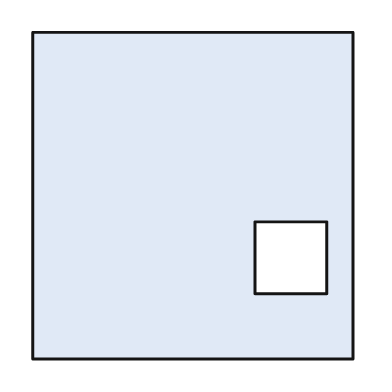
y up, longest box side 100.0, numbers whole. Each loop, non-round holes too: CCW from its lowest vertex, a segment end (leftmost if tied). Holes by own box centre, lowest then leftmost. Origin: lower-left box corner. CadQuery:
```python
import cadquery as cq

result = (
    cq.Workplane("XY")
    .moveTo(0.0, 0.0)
    .lineTo(98.0, 0.0)
    .lineTo(98.0, 100.0)
    .lineTo(0.0, 100.0)
    .close()
    .moveTo(68.0, 20.0)
    .lineTo(90.0, 20.0)
    .lineTo(90.0, 42.0)
    .lineTo(68.0, 42.0)
    .close()
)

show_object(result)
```